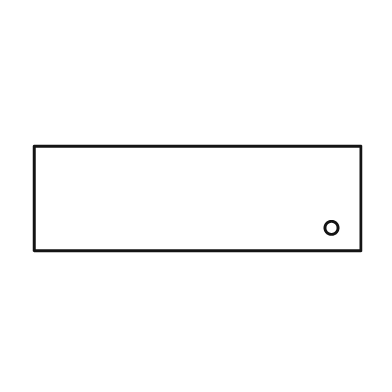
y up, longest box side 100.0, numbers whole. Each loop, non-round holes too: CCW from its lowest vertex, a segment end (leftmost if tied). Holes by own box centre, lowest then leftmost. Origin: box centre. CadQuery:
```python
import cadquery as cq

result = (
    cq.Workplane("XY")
    .moveTo(-50.0, -16.0)
    .lineTo(50.0, -16.0)
    .lineTo(50.0, 16.0)
    .lineTo(-50.0, 16.0)
    .close()
    .moveTo(41.0, -9.0)
    .circle(2.0)
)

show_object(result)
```